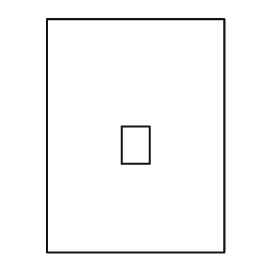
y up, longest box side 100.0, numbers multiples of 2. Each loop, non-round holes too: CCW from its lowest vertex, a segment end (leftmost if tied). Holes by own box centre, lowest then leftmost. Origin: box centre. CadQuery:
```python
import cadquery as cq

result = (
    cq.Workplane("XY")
    .moveTo(-38.0, -50.0)
    .lineTo(38.0, -50.0)
    .lineTo(38.0, 50.0)
    .lineTo(-38.0, 50.0)
    .close()
    .moveTo(-6.0, -12.0)
    .lineTo(6.0, -12.0)
    .lineTo(6.0, 4.0)
    .lineTo(-6.0, 4.0)
    .close()
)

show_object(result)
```